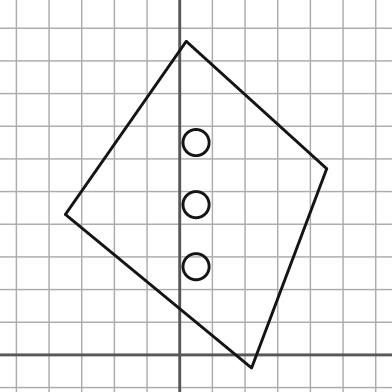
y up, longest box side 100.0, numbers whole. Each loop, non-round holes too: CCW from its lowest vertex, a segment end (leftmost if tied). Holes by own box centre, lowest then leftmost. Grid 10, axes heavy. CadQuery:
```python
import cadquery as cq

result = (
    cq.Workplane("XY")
    .moveTo(22.0, -4.0)
    .lineTo(45.0, 57.0)
    .lineTo(2.0, 96.0)
    .lineTo(-35.0, 43.0)
    .close()
    .moveTo(5.0, 27.0)
    .circle(4.0)
    .moveTo(5.0, 46.0)
    .circle(4.0)
    .moveTo(5.0, 65.0)
    .circle(4.0)
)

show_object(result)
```